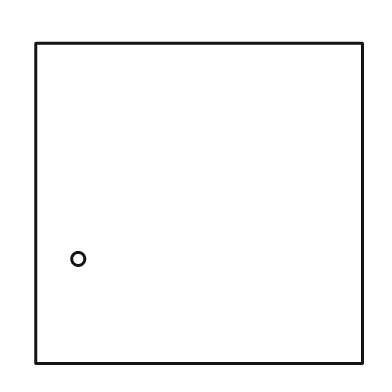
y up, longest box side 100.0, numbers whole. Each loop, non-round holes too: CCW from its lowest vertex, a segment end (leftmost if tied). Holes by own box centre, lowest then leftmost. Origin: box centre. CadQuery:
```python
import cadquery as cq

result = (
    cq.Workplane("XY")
    .moveTo(-50.0, -49.0)
    .lineTo(50.0, -49.0)
    .lineTo(50.0, 49.0)
    .lineTo(-50.0, 49.0)
    .close()
    .moveTo(-37.0, -17.0)
    .circle(2.0)
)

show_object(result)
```